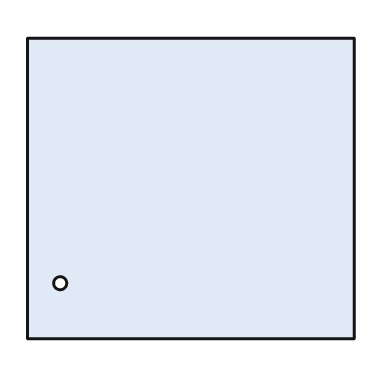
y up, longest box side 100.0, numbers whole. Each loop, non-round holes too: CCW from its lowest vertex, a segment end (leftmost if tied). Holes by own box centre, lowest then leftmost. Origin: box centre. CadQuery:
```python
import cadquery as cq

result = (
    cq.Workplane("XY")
    .moveTo(-50.0, -46.0)
    .lineTo(50.0, -46.0)
    .lineTo(50.0, 46.0)
    .lineTo(-50.0, 46.0)
    .close()
    .moveTo(-40.0, -29.0)
    .circle(2.0)
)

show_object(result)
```